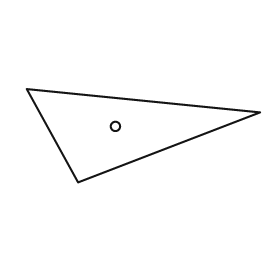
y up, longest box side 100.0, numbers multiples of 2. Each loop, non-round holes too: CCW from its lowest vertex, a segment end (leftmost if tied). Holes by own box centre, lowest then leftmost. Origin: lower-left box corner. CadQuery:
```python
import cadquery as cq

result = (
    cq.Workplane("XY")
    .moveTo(22.0, 0.0)
    .lineTo(100.0, 30.0)
    .lineTo(0.0, 40.0)
    .close()
    .moveTo(38.0, 24.0)
    .circle(2.0)
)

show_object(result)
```